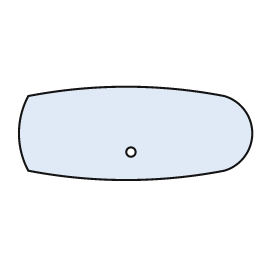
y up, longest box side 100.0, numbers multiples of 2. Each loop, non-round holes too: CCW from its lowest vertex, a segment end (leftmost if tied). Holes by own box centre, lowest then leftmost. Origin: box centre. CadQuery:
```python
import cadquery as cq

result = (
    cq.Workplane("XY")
    .moveTo(-46.0, -16.0)
    .threePointArc((-4.0, -20.0), (38.0, -16.0))
    .threePointArc((50.0, 0.0), (38.0, 16.0))
    .threePointArc((-4.0, 20.0), (-46.0, 16.0))
    .threePointArc((-50.0, 0.0), (-46.0, -16.0))
    .close()
    .moveTo(-2.0, -8.0)
    .circle(2.0)
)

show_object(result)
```